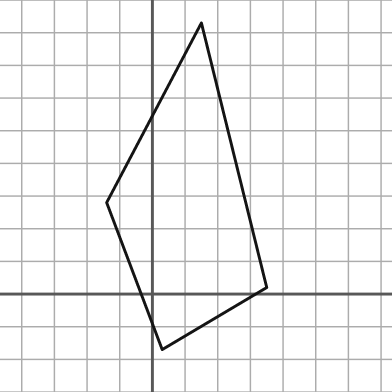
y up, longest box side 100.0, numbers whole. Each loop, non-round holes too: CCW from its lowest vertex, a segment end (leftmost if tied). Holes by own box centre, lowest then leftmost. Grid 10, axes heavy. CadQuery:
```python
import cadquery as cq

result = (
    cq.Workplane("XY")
    .moveTo(3.0, -17.0)
    .lineTo(35.0, 2.0)
    .lineTo(15.0, 83.0)
    .lineTo(-14.0, 28.0)
    .close()
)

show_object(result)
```